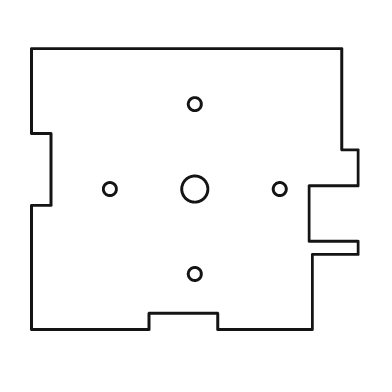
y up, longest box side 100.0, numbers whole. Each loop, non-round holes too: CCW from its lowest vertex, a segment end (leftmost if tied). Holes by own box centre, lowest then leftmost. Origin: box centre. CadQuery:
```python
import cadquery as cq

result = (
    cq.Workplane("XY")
    .moveTo(-50.0, -43.0)
    .lineTo(-14.0, -43.0)
    .lineTo(-14.0, -38.0)
    .lineTo(7.0, -38.0)
    .lineTo(7.0, -43.0)
    .lineTo(36.0, -43.0)
    .lineTo(36.0, -20.0)
    .lineTo(50.0, -20.0)
    .lineTo(50.0, -16.0)
    .lineTo(35.0, -16.0)
    .lineTo(35.0, 1.0)
    .lineTo(50.0, 1.0)
    .lineTo(50.0, 12.0)
    .lineTo(45.0, 12.0)
    .lineTo(45.0, 43.0)
    .lineTo(-50.0, 43.0)
    .lineTo(-50.0, 17.0)
    .lineTo(-44.0, 17.0)
    .lineTo(-44.0, -5.0)
    .lineTo(-50.0, -5.0)
    .close()
    .moveTo(0.0, -26.0)
    .circle(2.0)
    .moveTo(-26.0, 0.0)
    .circle(2.0)
    .moveTo(0.0, 0.0)
    .circle(4.0)
    .moveTo(26.0, 0.0)
    .circle(2.0)
    .moveTo(0.0, 26.0)
    .circle(2.0)
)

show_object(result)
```